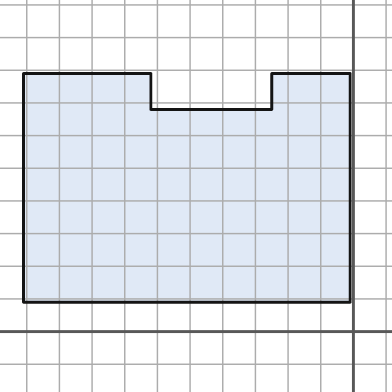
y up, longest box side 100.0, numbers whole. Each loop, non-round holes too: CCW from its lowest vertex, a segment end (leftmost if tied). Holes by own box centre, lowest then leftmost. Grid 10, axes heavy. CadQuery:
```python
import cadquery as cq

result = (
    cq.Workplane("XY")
    .moveTo(-101.0, 9.0)
    .lineTo(-1.0, 9.0)
    .lineTo(-1.0, 79.0)
    .lineTo(-25.0, 79.0)
    .lineTo(-25.0, 68.0)
    .lineTo(-62.0, 68.0)
    .lineTo(-62.0, 79.0)
    .lineTo(-101.0, 79.0)
    .close()
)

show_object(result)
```